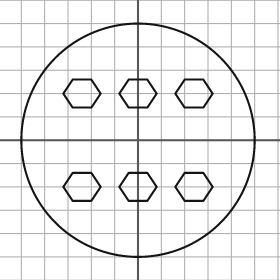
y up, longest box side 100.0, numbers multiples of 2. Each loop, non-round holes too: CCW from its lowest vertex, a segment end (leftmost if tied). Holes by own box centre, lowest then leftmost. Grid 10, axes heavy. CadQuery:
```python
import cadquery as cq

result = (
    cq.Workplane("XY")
    .moveTo(0.0, 0.0)
    .circle(50.0)
    .moveTo(-28.0, -26.0)
    .lineTo(-20.0, -26.0)
    .lineTo(-16.0, -20.0)
    .lineTo(-20.0, -14.0)
    .lineTo(-28.0, -14.0)
    .lineTo(-32.0, -20.0)
    .close()
    .moveTo(-4.0, -26.0)
    .lineTo(4.0, -26.0)
    .lineTo(8.0, -20.0)
    .lineTo(4.0, -14.0)
    .lineTo(-4.0, -14.0)
    .lineTo(-8.0, -20.0)
    .close()
    .moveTo(20.0, -26.0)
    .lineTo(28.0, -26.0)
    .lineTo(32.0, -20.0)
    .lineTo(28.0, -14.0)
    .lineTo(20.0, -14.0)
    .lineTo(16.0, -20.0)
    .close()
    .moveTo(-28.0, 14.0)
    .lineTo(-20.0, 14.0)
    .lineTo(-16.0, 20.0)
    .lineTo(-20.0, 26.0)
    .lineTo(-28.0, 26.0)
    .lineTo(-32.0, 20.0)
    .close()
    .moveTo(-4.0, 14.0)
    .lineTo(4.0, 14.0)
    .lineTo(8.0, 20.0)
    .lineTo(4.0, 26.0)
    .lineTo(-4.0, 26.0)
    .lineTo(-8.0, 20.0)
    .close()
    .moveTo(20.0, 14.0)
    .lineTo(28.0, 14.0)
    .lineTo(32.0, 20.0)
    .lineTo(28.0, 26.0)
    .lineTo(20.0, 26.0)
    .lineTo(16.0, 20.0)
    .close()
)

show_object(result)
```